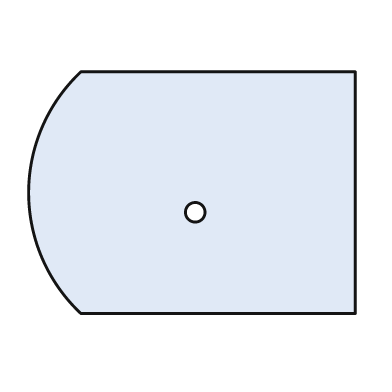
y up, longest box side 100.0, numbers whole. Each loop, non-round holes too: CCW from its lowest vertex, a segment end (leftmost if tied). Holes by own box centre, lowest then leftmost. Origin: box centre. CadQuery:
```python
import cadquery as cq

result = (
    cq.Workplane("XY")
    .moveTo(-34.0, -37.0)
    .lineTo(50.0, -37.0)
    .lineTo(50.0, 37.0)
    .lineTo(-34.0, 37.0)
    .threePointArc((-50.0, 0.0), (-34.0, -37.0))
    .close()
    .moveTo(1.0, -6.0)
    .circle(3.0)
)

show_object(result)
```